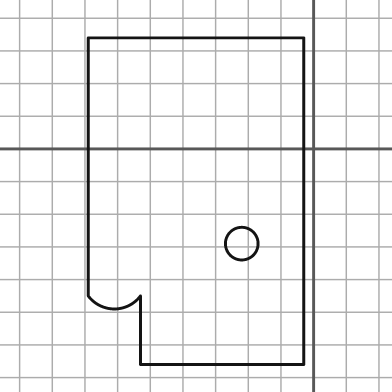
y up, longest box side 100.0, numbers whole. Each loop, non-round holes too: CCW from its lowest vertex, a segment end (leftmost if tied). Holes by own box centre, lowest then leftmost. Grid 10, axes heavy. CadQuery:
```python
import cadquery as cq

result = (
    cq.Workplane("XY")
    .moveTo(-53.0, -66.0)
    .lineTo(-3.0, -66.0)
    .lineTo(-3.0, 34.0)
    .lineTo(-69.0, 34.0)
    .lineTo(-69.0, -45.0)
    .threePointArc((-61.0, -49.0), (-53.0, -45.0))
    .close()
    .moveTo(-22.0, -29.0)
    .circle(5.0)
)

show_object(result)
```